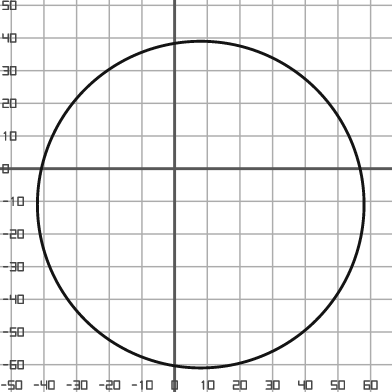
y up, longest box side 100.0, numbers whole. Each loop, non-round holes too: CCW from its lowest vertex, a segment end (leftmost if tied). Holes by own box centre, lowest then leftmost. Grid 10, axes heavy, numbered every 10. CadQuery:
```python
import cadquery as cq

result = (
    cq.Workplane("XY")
    .moveTo(8.0, -11.0)
    .circle(50.0)
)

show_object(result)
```